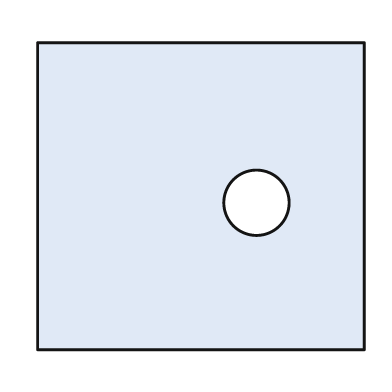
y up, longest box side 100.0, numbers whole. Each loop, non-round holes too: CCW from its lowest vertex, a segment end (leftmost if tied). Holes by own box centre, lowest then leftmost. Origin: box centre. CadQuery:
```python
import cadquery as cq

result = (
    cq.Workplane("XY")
    .moveTo(-50.0, -47.0)
    .lineTo(50.0, -47.0)
    .lineTo(50.0, 47.0)
    .lineTo(-50.0, 47.0)
    .close()
    .moveTo(17.0, -2.0)
    .circle(10.0)
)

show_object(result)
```